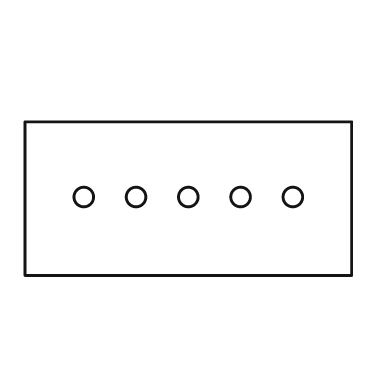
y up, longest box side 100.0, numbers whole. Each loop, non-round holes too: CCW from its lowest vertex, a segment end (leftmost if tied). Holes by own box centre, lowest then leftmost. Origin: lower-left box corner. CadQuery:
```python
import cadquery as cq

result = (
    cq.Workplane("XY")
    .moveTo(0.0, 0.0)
    .lineTo(100.0, 0.0)
    .lineTo(100.0, 47.0)
    .lineTo(0.0, 47.0)
    .close()
    .moveTo(18.0, 24.0)
    .circle(3.0)
    .moveTo(34.0, 24.0)
    .circle(3.0)
    .moveTo(50.0, 24.0)
    .circle(3.0)
    .moveTo(66.0, 24.0)
    .circle(3.0)
    .moveTo(82.0, 24.0)
    .circle(3.0)
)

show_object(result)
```